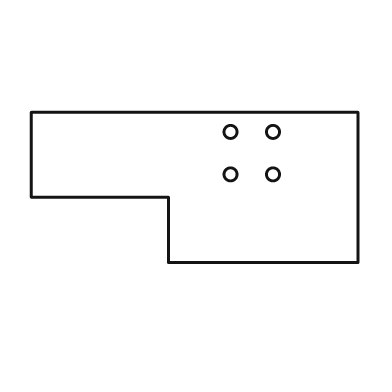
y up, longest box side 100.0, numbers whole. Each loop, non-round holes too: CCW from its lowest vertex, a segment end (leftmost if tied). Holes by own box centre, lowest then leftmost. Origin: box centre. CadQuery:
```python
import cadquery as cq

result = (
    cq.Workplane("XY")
    .moveTo(-8.0, -23.0)
    .lineTo(50.0, -23.0)
    .lineTo(50.0, 23.0)
    .lineTo(-50.0, 23.0)
    .lineTo(-50.0, -3.0)
    .lineTo(-8.0, -3.0)
    .close()
    .moveTo(11.0, 4.0)
    .circle(2.0)
    .moveTo(24.0, 4.0)
    .circle(2.0)
    .moveTo(11.0, 17.0)
    .circle(2.0)
    .moveTo(24.0, 17.0)
    .circle(2.0)
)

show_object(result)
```